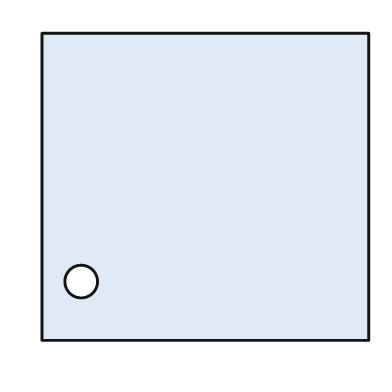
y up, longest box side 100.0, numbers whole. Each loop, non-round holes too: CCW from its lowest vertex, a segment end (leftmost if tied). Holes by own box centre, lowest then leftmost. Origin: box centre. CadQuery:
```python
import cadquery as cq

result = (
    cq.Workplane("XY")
    .moveTo(-50.0, -47.0)
    .lineTo(50.0, -47.0)
    .lineTo(50.0, 47.0)
    .lineTo(-50.0, 47.0)
    .close()
    .moveTo(-38.0, -29.0)
    .circle(5.0)
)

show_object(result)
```